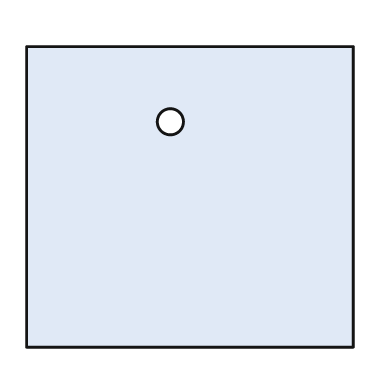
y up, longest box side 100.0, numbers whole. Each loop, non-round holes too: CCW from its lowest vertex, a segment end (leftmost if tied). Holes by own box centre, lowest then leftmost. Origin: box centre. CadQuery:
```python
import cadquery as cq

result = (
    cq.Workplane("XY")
    .moveTo(-50.0, -46.0)
    .lineTo(50.0, -46.0)
    .lineTo(50.0, 46.0)
    .lineTo(-50.0, 46.0)
    .close()
    .moveTo(-6.0, 23.0)
    .circle(4.0)
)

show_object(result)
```